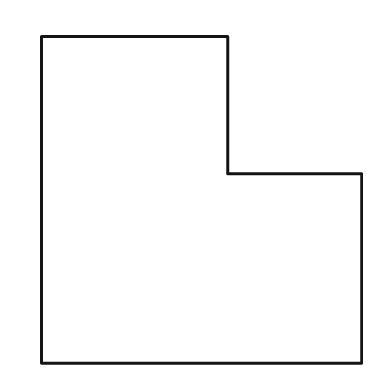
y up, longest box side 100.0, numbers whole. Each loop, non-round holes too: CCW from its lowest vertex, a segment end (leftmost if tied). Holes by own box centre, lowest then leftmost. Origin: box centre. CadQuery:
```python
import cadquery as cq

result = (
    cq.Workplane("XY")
    .moveTo(-49.0, -50.0)
    .lineTo(49.0, -50.0)
    .lineTo(49.0, 8.0)
    .lineTo(8.0, 8.0)
    .lineTo(8.0, 50.0)
    .lineTo(-49.0, 50.0)
    .close()
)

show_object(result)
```